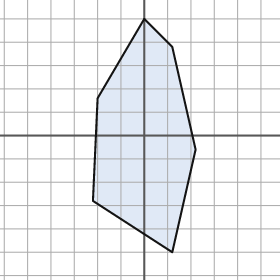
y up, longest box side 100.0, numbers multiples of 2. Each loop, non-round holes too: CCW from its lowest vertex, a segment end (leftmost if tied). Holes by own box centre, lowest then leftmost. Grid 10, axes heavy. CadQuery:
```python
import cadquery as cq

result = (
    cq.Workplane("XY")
    .moveTo(12.0, -50.0)
    .lineTo(22.0, -6.0)
    .lineTo(12.0, 38.0)
    .lineTo(0.0, 50.0)
    .lineTo(-20.0, 16.0)
    .lineTo(-22.0, -28.0)
    .close()
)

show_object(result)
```